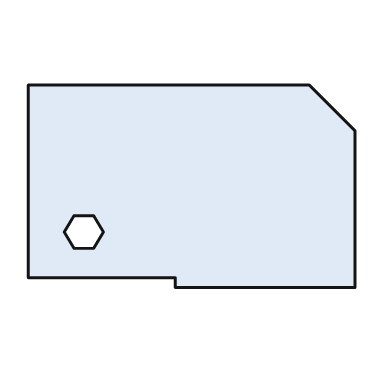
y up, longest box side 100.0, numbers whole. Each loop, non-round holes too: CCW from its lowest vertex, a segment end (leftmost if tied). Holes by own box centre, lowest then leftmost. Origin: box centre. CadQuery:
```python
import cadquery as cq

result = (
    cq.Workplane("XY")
    .moveTo(-5.0, -31.0)
    .lineTo(50.0, -31.0)
    .lineTo(50.0, 17.0)
    .lineTo(36.0, 31.0)
    .lineTo(-50.0, 31.0)
    .lineTo(-50.0, -28.0)
    .lineTo(-5.0, -28.0)
    .close()
    .moveTo(-36.0, -19.0)
    .lineTo(-30.0, -19.0)
    .lineTo(-27.0, -14.0)
    .lineTo(-30.0, -9.0)
    .lineTo(-36.0, -9.0)
    .lineTo(-39.0, -14.0)
    .close()
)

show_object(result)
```